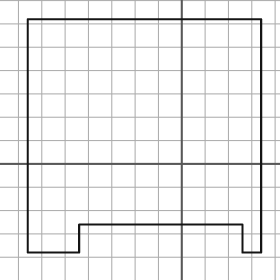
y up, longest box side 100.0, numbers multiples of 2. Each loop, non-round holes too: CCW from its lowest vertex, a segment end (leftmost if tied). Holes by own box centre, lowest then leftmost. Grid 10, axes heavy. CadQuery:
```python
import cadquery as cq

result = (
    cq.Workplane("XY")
    .moveTo(-66.0, -38.0)
    .lineTo(-44.0, -38.0)
    .lineTo(-44.0, -26.0)
    .lineTo(26.0, -26.0)
    .lineTo(26.0, -38.0)
    .lineTo(34.0, -38.0)
    .lineTo(34.0, 62.0)
    .lineTo(-66.0, 62.0)
    .close()
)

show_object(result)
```